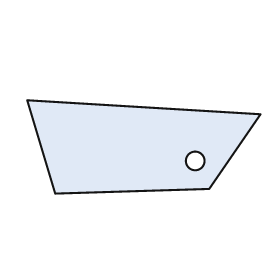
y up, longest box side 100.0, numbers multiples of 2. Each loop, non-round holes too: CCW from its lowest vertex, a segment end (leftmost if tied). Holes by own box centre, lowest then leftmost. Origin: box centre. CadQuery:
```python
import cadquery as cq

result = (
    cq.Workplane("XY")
    .moveTo(-38.0, -20.0)
    .lineTo(28.0, -18.0)
    .lineTo(50.0, 14.0)
    .lineTo(-50.0, 20.0)
    .close()
    .moveTo(22.0, -6.0)
    .circle(4.0)
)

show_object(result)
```